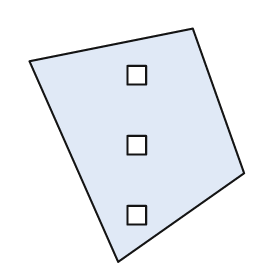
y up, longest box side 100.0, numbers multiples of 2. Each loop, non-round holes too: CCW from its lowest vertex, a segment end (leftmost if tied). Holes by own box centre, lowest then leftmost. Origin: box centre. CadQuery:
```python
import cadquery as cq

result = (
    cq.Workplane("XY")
    .moveTo(-8.0, -50.0)
    .lineTo(46.0, -12.0)
    .lineTo(24.0, 50.0)
    .lineTo(-46.0, 36.0)
    .close()
    .moveTo(-4.0, -34.0)
    .lineTo(4.0, -34.0)
    .lineTo(4.0, -26.0)
    .lineTo(-4.0, -26.0)
    .close()
    .moveTo(-4.0, -4.0)
    .lineTo(4.0, -4.0)
    .lineTo(4.0, 4.0)
    .lineTo(-4.0, 4.0)
    .close()
    .moveTo(-4.0, 26.0)
    .lineTo(4.0, 26.0)
    .lineTo(4.0, 34.0)
    .lineTo(-4.0, 34.0)
    .close()
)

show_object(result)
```